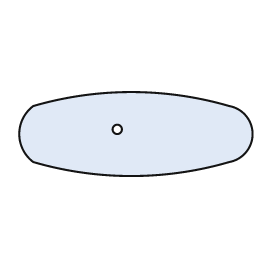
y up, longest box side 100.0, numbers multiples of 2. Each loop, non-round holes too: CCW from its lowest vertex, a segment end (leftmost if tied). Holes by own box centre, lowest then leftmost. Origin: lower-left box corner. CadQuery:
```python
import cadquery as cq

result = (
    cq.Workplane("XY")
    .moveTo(6.0, 6.0)
    .threePointArc((48.0, 0.0), (90.0, 6.0))
    .threePointArc((100.0, 18.0), (90.0, 30.0))
    .threePointArc((48.0, 36.0), (6.0, 30.0))
    .threePointArc((0.0, 18.0), (6.0, 6.0))
    .close()
    .moveTo(42.0, 20.0)
    .circle(2.0)
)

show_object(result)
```